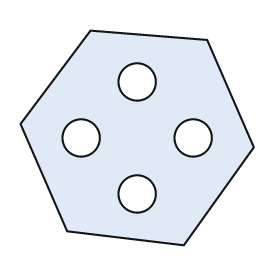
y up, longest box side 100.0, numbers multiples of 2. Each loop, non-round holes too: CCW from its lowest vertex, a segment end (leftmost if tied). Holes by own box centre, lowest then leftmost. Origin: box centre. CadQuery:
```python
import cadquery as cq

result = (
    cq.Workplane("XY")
    .moveTo(20.0, -46.0)
    .lineTo(50.0, -4.0)
    .lineTo(30.0, 42.0)
    .lineTo(-20.0, 46.0)
    .lineTo(-50.0, 6.0)
    .lineTo(-30.0, -40.0)
    .close()
    .moveTo(0.0, -24.0)
    .circle(8.0)
    .moveTo(-24.0, 0.0)
    .circle(8.0)
    .moveTo(24.0, 0.0)
    .circle(8.0)
    .moveTo(0.0, 24.0)
    .circle(8.0)
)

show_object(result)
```